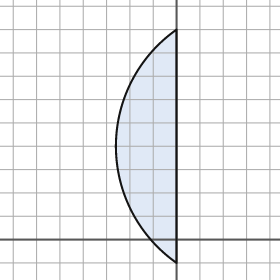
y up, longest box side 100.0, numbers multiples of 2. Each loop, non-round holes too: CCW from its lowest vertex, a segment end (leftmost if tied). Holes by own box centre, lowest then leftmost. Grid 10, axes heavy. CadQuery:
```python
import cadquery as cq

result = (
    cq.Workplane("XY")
    .moveTo(0.0, -10.0)
    .lineTo(0.0, 90.0)
    .threePointArc((-26.0, 40.0), (0.0, -10.0))
    .close()
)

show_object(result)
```